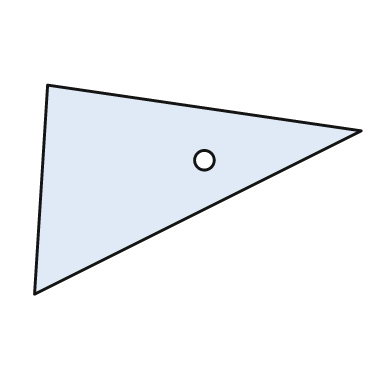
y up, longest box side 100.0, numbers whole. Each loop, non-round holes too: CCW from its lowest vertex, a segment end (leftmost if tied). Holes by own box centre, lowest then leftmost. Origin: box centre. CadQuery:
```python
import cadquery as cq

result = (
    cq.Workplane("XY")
    .moveTo(-50.0, -32.0)
    .lineTo(50.0, 18.0)
    .lineTo(-46.0, 32.0)
    .close()
    .moveTo(2.0, 9.0)
    .circle(3.0)
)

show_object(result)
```